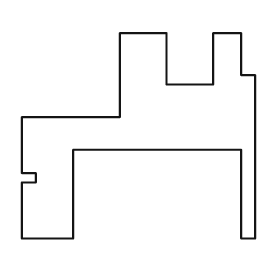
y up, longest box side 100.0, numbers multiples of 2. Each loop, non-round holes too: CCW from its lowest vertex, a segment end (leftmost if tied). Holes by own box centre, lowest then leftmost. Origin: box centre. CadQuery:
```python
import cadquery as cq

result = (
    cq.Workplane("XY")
    .moveTo(-50.0, -44.0)
    .lineTo(-28.0, -44.0)
    .lineTo(-28.0, -6.0)
    .lineTo(44.0, -6.0)
    .lineTo(44.0, -44.0)
    .lineTo(50.0, -44.0)
    .lineTo(50.0, 26.0)
    .lineTo(44.0, 26.0)
    .lineTo(44.0, 44.0)
    .lineTo(32.0, 44.0)
    .lineTo(32.0, 22.0)
    .lineTo(12.0, 22.0)
    .lineTo(12.0, 44.0)
    .lineTo(-8.0, 44.0)
    .lineTo(-8.0, 8.0)
    .lineTo(-50.0, 8.0)
    .lineTo(-50.0, -16.0)
    .lineTo(-44.0, -16.0)
    .lineTo(-44.0, -20.0)
    .lineTo(-50.0, -20.0)
    .close()
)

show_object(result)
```